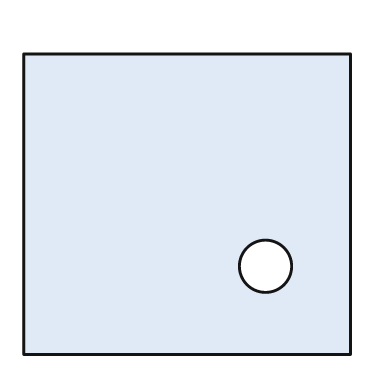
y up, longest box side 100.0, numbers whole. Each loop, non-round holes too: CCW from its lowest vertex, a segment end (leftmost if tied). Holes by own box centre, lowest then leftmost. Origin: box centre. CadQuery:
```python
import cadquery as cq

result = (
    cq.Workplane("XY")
    .moveTo(-50.0, -46.0)
    .lineTo(50.0, -46.0)
    .lineTo(50.0, 46.0)
    .lineTo(-50.0, 46.0)
    .close()
    .moveTo(24.0, -19.0)
    .circle(8.0)
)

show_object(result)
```